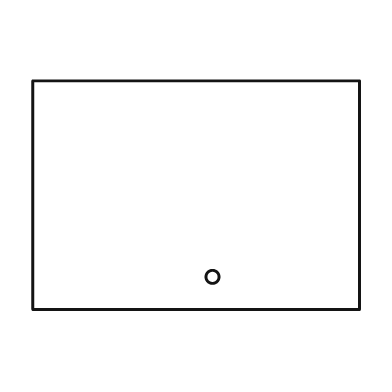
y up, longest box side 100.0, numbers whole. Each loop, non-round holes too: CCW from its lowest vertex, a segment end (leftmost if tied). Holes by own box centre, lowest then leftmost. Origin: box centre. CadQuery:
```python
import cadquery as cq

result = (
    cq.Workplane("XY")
    .moveTo(-50.0, -35.0)
    .lineTo(50.0, -35.0)
    .lineTo(50.0, 35.0)
    .lineTo(-50.0, 35.0)
    .close()
    .moveTo(5.0, -25.0)
    .circle(2.0)
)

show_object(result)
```